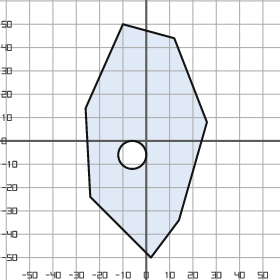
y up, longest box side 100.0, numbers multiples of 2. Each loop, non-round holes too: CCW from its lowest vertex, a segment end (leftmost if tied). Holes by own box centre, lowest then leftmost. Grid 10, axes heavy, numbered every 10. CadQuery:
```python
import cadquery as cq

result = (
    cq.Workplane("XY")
    .moveTo(2.0, -50.0)
    .lineTo(14.0, -34.0)
    .lineTo(26.0, 8.0)
    .lineTo(12.0, 44.0)
    .lineTo(-10.0, 50.0)
    .lineTo(-26.0, 14.0)
    .lineTo(-24.0, -24.0)
    .close()
    .moveTo(-6.0, -6.0)
    .circle(6.0)
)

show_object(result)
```